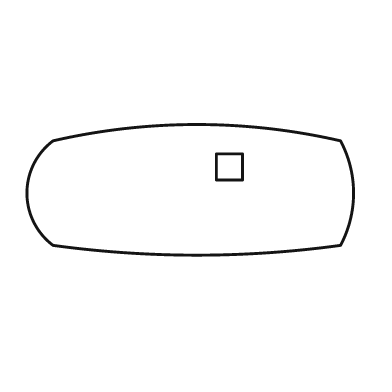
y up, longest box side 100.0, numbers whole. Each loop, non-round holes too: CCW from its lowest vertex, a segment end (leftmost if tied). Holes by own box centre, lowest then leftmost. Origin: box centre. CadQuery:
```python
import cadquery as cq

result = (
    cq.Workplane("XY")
    .moveTo(-42.0, -17.0)
    .threePointArc((2.0, -20.0), (46.0, -17.0))
    .threePointArc((50.0, -1.0), (46.0, 15.0))
    .threePointArc((2.0, 20.0), (-42.0, 15.0))
    .threePointArc((-50.0, -1.0), (-42.0, -17.0))
    .close()
    .moveTo(8.0, 3.0)
    .lineTo(16.0, 3.0)
    .lineTo(16.0, 11.0)
    .lineTo(8.0, 11.0)
    .close()
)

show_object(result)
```